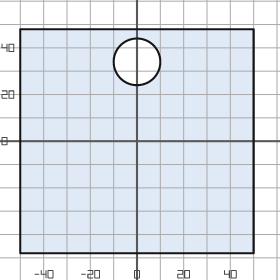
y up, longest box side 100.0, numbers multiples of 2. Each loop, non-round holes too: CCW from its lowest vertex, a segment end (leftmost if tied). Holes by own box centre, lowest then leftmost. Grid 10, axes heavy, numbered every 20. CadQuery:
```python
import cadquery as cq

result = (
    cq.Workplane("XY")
    .moveTo(-50.0, -48.0)
    .lineTo(50.0, -48.0)
    .lineTo(50.0, 48.0)
    .lineTo(-50.0, 48.0)
    .close()
    .moveTo(0.0, 34.0)
    .circle(10.0)
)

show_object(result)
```